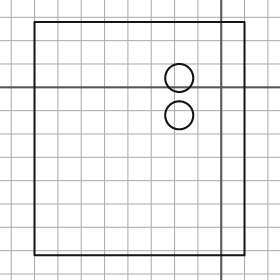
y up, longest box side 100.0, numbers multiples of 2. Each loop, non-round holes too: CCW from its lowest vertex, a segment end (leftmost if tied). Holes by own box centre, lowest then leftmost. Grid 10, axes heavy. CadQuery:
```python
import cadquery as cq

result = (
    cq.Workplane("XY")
    .moveTo(-80.0, -72.0)
    .lineTo(10.0, -72.0)
    .lineTo(10.0, 28.0)
    .lineTo(-80.0, 28.0)
    .close()
    .moveTo(-18.0, -12.0)
    .circle(6.0)
    .moveTo(-18.0, 4.0)
    .circle(6.0)
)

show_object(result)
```